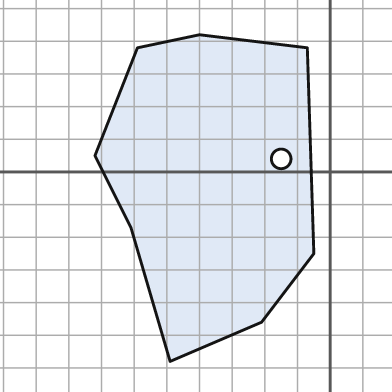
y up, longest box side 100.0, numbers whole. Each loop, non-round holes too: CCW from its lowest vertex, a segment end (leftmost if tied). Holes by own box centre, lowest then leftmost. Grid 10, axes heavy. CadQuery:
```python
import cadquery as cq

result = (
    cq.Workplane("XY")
    .moveTo(-49.0, -58.0)
    .lineTo(-21.0, -46.0)
    .lineTo(-5.0, -25.0)
    .lineTo(-7.0, 38.0)
    .lineTo(-40.0, 42.0)
    .lineTo(-59.0, 38.0)
    .lineTo(-72.0, 5.0)
    .lineTo(-61.0, -17.0)
    .close()
    .moveTo(-15.0, 4.0)
    .circle(3.0)
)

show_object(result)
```